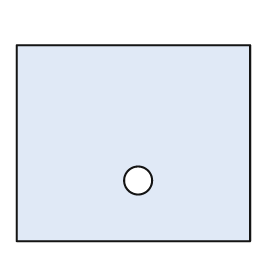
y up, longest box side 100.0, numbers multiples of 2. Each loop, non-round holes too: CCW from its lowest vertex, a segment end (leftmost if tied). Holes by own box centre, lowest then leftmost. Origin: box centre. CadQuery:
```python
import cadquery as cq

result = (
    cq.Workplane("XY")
    .moveTo(-50.0, -42.0)
    .lineTo(50.0, -42.0)
    .lineTo(50.0, 42.0)
    .lineTo(-50.0, 42.0)
    .close()
    .moveTo(2.0, -16.0)
    .circle(6.0)
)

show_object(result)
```